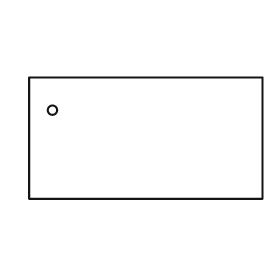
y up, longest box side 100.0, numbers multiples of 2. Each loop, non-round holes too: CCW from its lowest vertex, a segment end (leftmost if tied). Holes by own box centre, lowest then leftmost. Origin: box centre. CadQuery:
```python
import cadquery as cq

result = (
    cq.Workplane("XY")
    .moveTo(-50.0, -26.0)
    .lineTo(50.0, -26.0)
    .lineTo(50.0, 26.0)
    .lineTo(-50.0, 26.0)
    .close()
    .moveTo(-40.0, 12.0)
    .circle(2.0)
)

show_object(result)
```